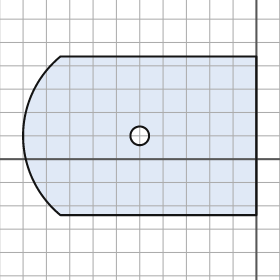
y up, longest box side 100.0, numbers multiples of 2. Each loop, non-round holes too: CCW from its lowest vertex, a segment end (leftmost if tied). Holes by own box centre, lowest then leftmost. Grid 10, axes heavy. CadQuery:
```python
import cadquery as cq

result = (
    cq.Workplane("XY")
    .moveTo(-84.0, -24.0)
    .lineTo(0.0, -24.0)
    .lineTo(0.0, 44.0)
    .lineTo(-84.0, 44.0)
    .threePointArc((-100.0, 10.0), (-84.0, -24.0))
    .close()
    .moveTo(-50.0, 10.0)
    .circle(4.0)
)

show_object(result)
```